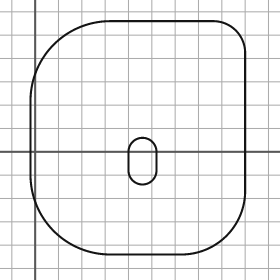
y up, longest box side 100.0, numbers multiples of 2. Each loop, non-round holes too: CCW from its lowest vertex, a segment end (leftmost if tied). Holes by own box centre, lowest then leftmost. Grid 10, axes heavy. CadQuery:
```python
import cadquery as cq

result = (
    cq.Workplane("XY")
    .moveTo(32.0, -44.0)
    .lineTo(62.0, -44.0)
    .threePointArc((82.0, -36.0), (90.0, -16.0))
    .lineTo(90.0, 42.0)
    .threePointArc((86.0, 52.0), (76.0, 56.0))
    .lineTo(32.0, 56.0)
    .threePointArc((8.0, 46.0), (-2.0, 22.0))
    .lineTo(-2.0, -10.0)
    .threePointArc((8.0, -34.0), (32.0, -44.0))
    .close()
    .moveTo(40.0, -8.0)
    .threePointArc((46.0, -14.0), (52.0, -8.0))
    .lineTo(52.0, 0.0)
    .threePointArc((46.0, 6.0), (40.0, 0.0))
    .close()
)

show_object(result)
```